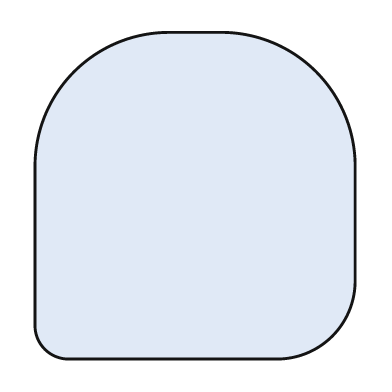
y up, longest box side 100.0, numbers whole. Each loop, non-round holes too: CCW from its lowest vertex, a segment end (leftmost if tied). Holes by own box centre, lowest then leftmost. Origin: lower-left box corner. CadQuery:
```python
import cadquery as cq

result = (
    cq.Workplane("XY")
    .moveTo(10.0, 0.0)
    .lineTo(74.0, 0.0)
    .threePointArc((91.0, 7.0), (98.0, 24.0))
    .lineTo(98.0, 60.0)
    .threePointArc((86.0, 88.0), (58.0, 100.0))
    .lineTo(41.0, 100.0)
    .threePointArc((12.0, 88.0), (0.0, 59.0))
    .lineTo(0.0, 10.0)
    .threePointArc((3.0, 3.0), (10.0, 0.0))
    .close()
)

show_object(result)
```